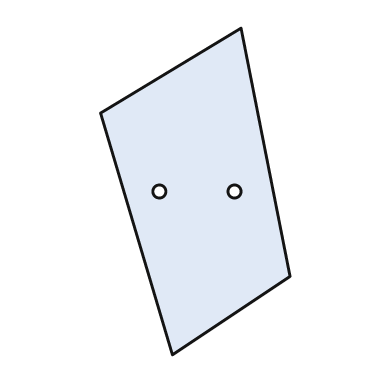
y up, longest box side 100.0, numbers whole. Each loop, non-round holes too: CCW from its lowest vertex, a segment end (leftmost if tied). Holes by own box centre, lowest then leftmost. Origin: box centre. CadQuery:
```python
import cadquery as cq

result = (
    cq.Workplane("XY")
    .moveTo(-7.0, -50.0)
    .lineTo(29.0, -26.0)
    .lineTo(14.0, 50.0)
    .lineTo(-29.0, 24.0)
    .close()
    .moveTo(-11.0, 0.0)
    .circle(2.0)
    .moveTo(12.0, 0.0)
    .circle(2.0)
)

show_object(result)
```